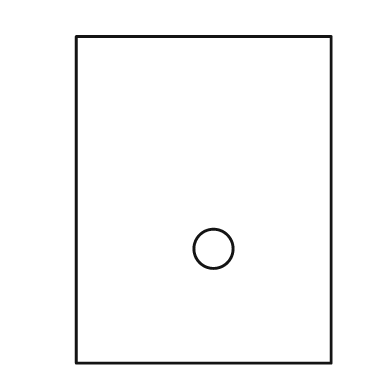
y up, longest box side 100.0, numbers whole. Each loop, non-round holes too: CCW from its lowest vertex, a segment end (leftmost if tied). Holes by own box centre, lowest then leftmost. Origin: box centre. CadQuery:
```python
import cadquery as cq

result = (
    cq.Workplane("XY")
    .moveTo(-39.0, -50.0)
    .lineTo(39.0, -50.0)
    .lineTo(39.0, 50.0)
    .lineTo(-39.0, 50.0)
    .close()
    .moveTo(3.0, -15.0)
    .circle(6.0)
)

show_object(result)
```